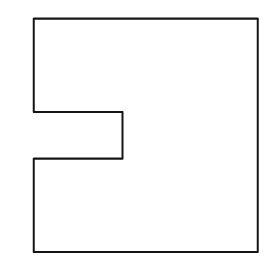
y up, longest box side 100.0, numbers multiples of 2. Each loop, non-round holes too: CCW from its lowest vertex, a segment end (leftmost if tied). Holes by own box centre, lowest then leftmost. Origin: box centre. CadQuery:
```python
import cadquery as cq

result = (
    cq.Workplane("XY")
    .moveTo(-48.0, -50.0)
    .lineTo(48.0, -50.0)
    .lineTo(48.0, 50.0)
    .lineTo(-48.0, 50.0)
    .lineTo(-48.0, 10.0)
    .lineTo(-10.0, 10.0)
    .lineTo(-10.0, -10.0)
    .lineTo(-48.0, -10.0)
    .close()
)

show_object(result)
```